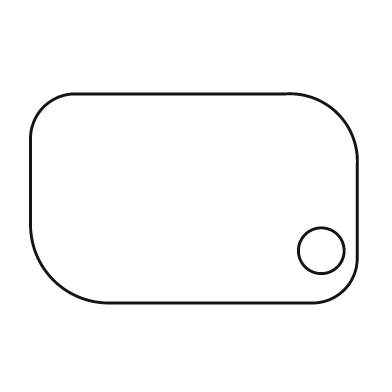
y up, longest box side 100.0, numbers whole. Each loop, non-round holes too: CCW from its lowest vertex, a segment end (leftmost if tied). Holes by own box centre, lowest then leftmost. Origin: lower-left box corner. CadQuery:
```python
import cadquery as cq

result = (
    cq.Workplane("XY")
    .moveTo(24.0, 0.0)
    .lineTo(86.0, 0.0)
    .threePointArc((96.0, 4.0), (100.0, 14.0))
    .lineTo(100.0, 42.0)
    .threePointArc((94.0, 58.0), (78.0, 64.0))
    .lineTo(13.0, 64.0)
    .threePointArc((4.0, 60.0), (0.0, 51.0))
    .lineTo(0.0, 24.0)
    .threePointArc((7.0, 7.0), (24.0, 0.0))
    .close()
    .moveTo(89.0, 16.0)
    .circle(7.0)
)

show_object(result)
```